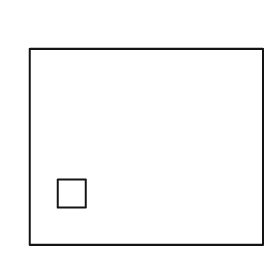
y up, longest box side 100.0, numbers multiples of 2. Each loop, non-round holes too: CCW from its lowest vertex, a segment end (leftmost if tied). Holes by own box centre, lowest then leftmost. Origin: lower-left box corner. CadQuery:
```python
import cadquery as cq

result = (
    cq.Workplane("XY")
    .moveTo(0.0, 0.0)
    .lineTo(100.0, 0.0)
    .lineTo(100.0, 84.0)
    .lineTo(0.0, 84.0)
    .close()
    .moveTo(12.0, 16.0)
    .lineTo(24.0, 16.0)
    .lineTo(24.0, 28.0)
    .lineTo(12.0, 28.0)
    .close()
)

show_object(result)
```